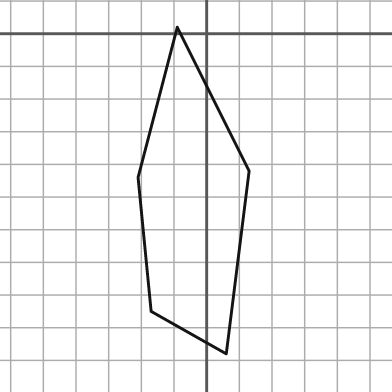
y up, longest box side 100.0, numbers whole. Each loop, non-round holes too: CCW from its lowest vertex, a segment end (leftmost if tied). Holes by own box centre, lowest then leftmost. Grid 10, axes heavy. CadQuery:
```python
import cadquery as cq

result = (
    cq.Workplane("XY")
    .moveTo(6.0, -98.0)
    .lineTo(13.0, -42.0)
    .lineTo(-9.0, 2.0)
    .lineTo(-21.0, -44.0)
    .lineTo(-17.0, -85.0)
    .close()
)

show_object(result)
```